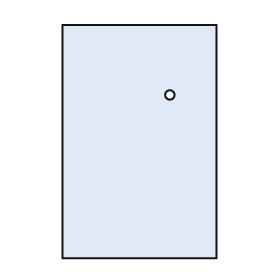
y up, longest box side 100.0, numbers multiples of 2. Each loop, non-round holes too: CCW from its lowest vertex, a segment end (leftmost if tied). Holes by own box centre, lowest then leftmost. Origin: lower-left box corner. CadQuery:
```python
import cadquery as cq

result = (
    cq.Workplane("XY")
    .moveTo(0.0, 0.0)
    .lineTo(66.0, 0.0)
    .lineTo(66.0, 100.0)
    .lineTo(0.0, 100.0)
    .close()
    .moveTo(46.0, 70.0)
    .circle(2.0)
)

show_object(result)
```